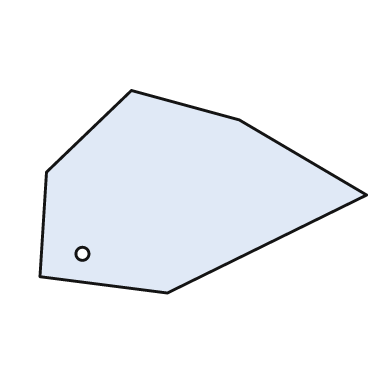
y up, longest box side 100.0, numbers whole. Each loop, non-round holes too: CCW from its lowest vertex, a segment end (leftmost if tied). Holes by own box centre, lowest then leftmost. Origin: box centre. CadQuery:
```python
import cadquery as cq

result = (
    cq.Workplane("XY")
    .moveTo(-11.0, -31.0)
    .lineTo(50.0, -1.0)
    .lineTo(11.0, 22.0)
    .lineTo(-22.0, 31.0)
    .lineTo(-48.0, 6.0)
    .lineTo(-50.0, -26.0)
    .close()
    .moveTo(-37.0, -19.0)
    .circle(2.0)
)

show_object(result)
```